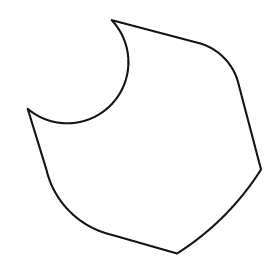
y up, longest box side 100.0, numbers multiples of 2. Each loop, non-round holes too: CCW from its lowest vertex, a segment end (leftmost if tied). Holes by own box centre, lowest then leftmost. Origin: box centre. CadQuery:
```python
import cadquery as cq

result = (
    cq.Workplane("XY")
    .moveTo(14.0, -50.0)
    .threePointArc((34.0, -34.0), (50.0, -14.0))
    .lineTo(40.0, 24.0)
    .threePointArc((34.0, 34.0), (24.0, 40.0))
    .lineTo(-14.0, 50.0)
    .threePointArc((-14.0, 14.0), (-50.0, 12.0))
    .lineTo(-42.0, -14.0)
    .threePointArc((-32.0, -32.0), (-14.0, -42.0))
    .close()
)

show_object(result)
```